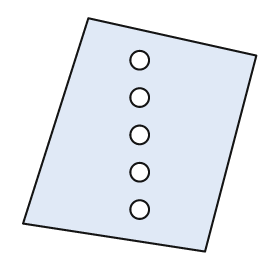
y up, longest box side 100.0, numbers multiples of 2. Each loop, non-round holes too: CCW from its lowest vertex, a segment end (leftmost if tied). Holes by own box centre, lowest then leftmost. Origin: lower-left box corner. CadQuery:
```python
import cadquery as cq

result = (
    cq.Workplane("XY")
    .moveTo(78.0, 0.0)
    .lineTo(100.0, 84.0)
    .lineTo(28.0, 100.0)
    .lineTo(0.0, 12.0)
    .close()
    .moveTo(50.0, 18.0)
    .circle(4.0)
    .moveTo(50.0, 34.0)
    .circle(4.0)
    .moveTo(50.0, 50.0)
    .circle(4.0)
    .moveTo(50.0, 66.0)
    .circle(4.0)
    .moveTo(50.0, 82.0)
    .circle(4.0)
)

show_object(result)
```